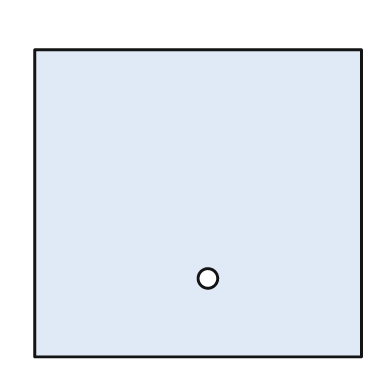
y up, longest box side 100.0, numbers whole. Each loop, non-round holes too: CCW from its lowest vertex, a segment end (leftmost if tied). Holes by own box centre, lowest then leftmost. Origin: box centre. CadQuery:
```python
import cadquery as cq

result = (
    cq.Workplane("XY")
    .moveTo(-50.0, -47.0)
    .lineTo(50.0, -47.0)
    .lineTo(50.0, 47.0)
    .lineTo(-50.0, 47.0)
    .close()
    .moveTo(3.0, -23.0)
    .circle(3.0)
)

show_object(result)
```